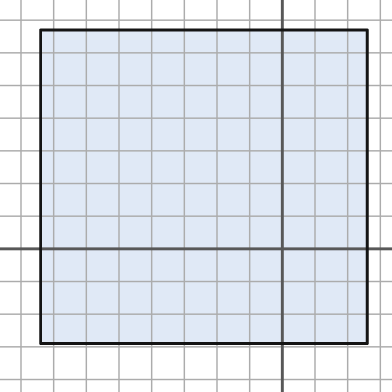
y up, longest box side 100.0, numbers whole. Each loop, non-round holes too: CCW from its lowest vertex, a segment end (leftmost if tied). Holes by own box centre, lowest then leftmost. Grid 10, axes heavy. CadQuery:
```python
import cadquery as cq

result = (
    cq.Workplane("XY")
    .moveTo(-74.0, -29.0)
    .lineTo(26.0, -29.0)
    .lineTo(26.0, 67.0)
    .lineTo(-74.0, 67.0)
    .close()
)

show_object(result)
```